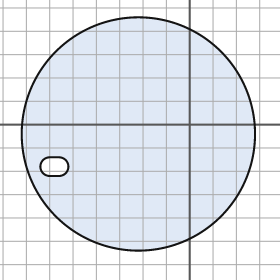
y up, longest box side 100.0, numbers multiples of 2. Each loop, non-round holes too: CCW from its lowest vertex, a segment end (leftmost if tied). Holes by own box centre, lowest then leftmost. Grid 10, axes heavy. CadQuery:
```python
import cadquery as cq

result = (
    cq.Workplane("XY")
    .moveTo(-22.0, -4.0)
    .circle(50.0)
    .moveTo(-60.0, -22.0)
    .lineTo(-56.0, -22.0)
    .threePointArc((-52.0, -18.0), (-56.0, -14.0))
    .lineTo(-60.0, -14.0)
    .threePointArc((-64.0, -18.0), (-60.0, -22.0))
    .close()
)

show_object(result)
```